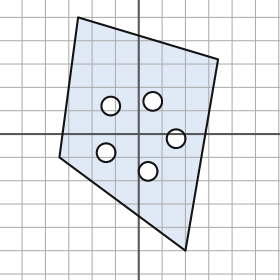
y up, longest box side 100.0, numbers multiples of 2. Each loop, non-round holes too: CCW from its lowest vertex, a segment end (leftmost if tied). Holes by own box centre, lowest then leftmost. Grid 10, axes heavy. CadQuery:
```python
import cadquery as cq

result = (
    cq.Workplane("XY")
    .moveTo(20.0, -50.0)
    .lineTo(34.0, 32.0)
    .lineTo(-26.0, 50.0)
    .lineTo(-34.0, -10.0)
    .close()
    .moveTo(4.0, -16.0)
    .circle(4.0)
    .moveTo(-14.0, -8.0)
    .circle(4.0)
    .moveTo(16.0, -2.0)
    .circle(4.0)
    .moveTo(-12.0, 12.0)
    .circle(4.0)
    .moveTo(6.0, 14.0)
    .circle(4.0)
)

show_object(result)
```